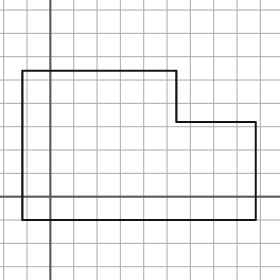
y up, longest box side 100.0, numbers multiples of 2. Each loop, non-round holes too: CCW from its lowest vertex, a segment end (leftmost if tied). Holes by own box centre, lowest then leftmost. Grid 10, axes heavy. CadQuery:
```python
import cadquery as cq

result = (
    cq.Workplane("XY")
    .moveTo(-12.0, -10.0)
    .lineTo(88.0, -10.0)
    .lineTo(88.0, 32.0)
    .lineTo(54.0, 32.0)
    .lineTo(54.0, 54.0)
    .lineTo(-12.0, 54.0)
    .close()
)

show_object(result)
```